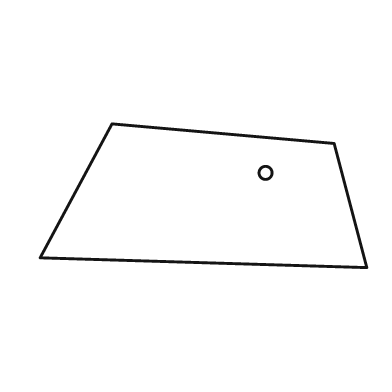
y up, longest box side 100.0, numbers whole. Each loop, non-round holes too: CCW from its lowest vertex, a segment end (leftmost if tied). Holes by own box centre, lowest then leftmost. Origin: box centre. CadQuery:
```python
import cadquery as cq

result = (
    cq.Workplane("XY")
    .moveTo(50.0, -22.0)
    .lineTo(40.0, 16.0)
    .lineTo(-28.0, 22.0)
    .lineTo(-50.0, -19.0)
    .close()
    .moveTo(19.0, 7.0)
    .circle(2.0)
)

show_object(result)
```